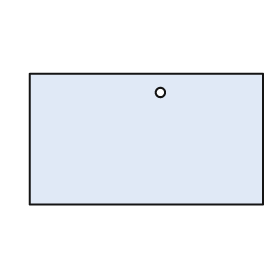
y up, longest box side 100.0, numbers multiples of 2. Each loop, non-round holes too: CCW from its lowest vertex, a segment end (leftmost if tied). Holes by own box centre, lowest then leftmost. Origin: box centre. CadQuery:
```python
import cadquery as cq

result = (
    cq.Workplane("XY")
    .moveTo(-50.0, -28.0)
    .lineTo(50.0, -28.0)
    .lineTo(50.0, 28.0)
    .lineTo(-50.0, 28.0)
    .close()
    .moveTo(6.0, 20.0)
    .circle(2.0)
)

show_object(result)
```